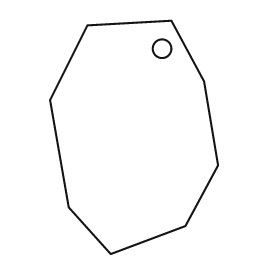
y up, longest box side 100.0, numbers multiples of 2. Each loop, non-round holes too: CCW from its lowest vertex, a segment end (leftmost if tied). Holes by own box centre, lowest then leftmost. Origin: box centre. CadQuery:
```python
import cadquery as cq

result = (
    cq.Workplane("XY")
    .moveTo(-10.0, -50.0)
    .lineTo(22.0, -38.0)
    .lineTo(36.0, -12.0)
    .lineTo(30.0, 24.0)
    .lineTo(16.0, 50.0)
    .lineTo(-20.0, 48.0)
    .lineTo(-36.0, 16.0)
    .lineTo(-28.0, -30.0)
    .close()
    .moveTo(12.0, 38.0)
    .circle(4.0)
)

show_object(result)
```